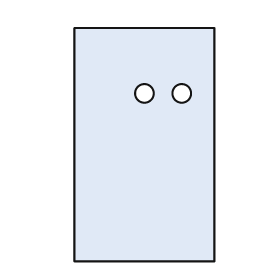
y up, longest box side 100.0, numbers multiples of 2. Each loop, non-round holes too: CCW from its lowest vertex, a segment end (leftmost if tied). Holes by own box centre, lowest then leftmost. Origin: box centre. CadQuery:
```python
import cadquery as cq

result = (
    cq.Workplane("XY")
    .moveTo(-30.0, -50.0)
    .lineTo(30.0, -50.0)
    .lineTo(30.0, 50.0)
    .lineTo(-30.0, 50.0)
    .close()
    .moveTo(0.0, 22.0)
    .circle(4.0)
    .moveTo(16.0, 22.0)
    .circle(4.0)
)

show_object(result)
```